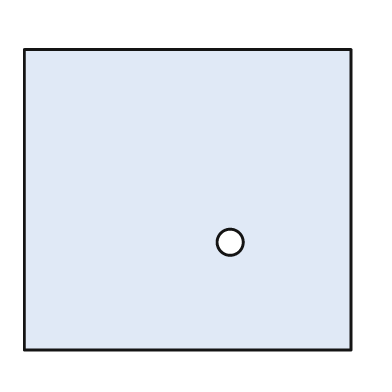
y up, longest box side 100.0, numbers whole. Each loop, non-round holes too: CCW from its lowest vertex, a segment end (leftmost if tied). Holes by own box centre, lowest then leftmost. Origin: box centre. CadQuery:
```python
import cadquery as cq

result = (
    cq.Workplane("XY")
    .moveTo(-50.0, -46.0)
    .lineTo(50.0, -46.0)
    .lineTo(50.0, 46.0)
    .lineTo(-50.0, 46.0)
    .close()
    .moveTo(13.0, -13.0)
    .circle(4.0)
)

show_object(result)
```